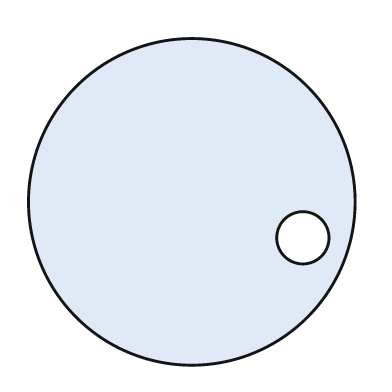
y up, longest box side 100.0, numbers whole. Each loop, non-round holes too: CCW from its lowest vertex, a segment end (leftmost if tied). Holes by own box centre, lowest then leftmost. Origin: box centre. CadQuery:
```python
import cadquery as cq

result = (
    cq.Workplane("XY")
    .moveTo(0.0, 0.0)
    .circle(50.0)
    .moveTo(34.0, -11.0)
    .circle(8.0)
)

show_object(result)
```